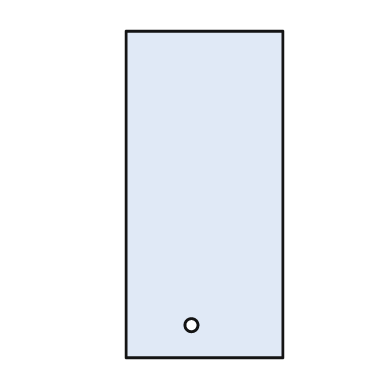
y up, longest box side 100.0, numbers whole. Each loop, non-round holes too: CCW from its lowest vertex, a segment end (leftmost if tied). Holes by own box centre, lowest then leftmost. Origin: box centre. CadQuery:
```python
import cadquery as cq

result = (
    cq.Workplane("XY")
    .moveTo(-24.0, -50.0)
    .lineTo(24.0, -50.0)
    .lineTo(24.0, 50.0)
    .lineTo(-24.0, 50.0)
    .close()
    .moveTo(-4.0, -40.0)
    .circle(2.0)
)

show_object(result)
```